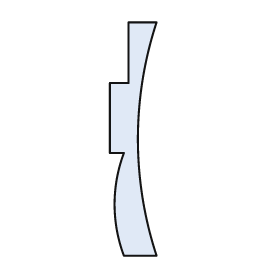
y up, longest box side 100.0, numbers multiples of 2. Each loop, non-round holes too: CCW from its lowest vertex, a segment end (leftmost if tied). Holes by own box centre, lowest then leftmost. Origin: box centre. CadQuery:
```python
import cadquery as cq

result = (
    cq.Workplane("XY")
    .moveTo(-4.0, -50.0)
    .lineTo(10.0, -50.0)
    .threePointArc((2.0, 0.0), (10.0, 50.0))
    .lineTo(-2.0, 50.0)
    .lineTo(-2.0, 24.0)
    .lineTo(-10.0, 24.0)
    .lineTo(-10.0, -6.0)
    .lineTo(-4.0, -6.0)
    .threePointArc((-8.0, -28.0), (-4.0, -50.0))
    .close()
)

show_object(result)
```